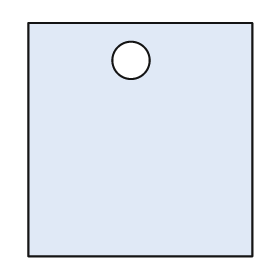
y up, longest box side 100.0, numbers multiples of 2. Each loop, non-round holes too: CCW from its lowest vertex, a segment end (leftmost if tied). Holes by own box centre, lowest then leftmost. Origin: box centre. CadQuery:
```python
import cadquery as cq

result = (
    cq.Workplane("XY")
    .moveTo(-48.0, -50.0)
    .lineTo(48.0, -50.0)
    .lineTo(48.0, 50.0)
    .lineTo(-48.0, 50.0)
    .close()
    .moveTo(-4.0, 34.0)
    .circle(8.0)
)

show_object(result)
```